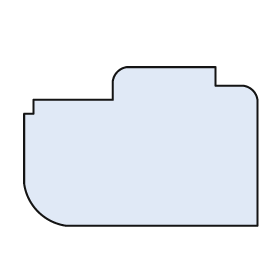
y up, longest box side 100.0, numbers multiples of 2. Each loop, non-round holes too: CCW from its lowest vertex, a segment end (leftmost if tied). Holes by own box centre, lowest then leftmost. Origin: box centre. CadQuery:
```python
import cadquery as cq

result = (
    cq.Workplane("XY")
    .moveTo(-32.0, -34.0)
    .lineTo(50.0, -34.0)
    .lineTo(50.0, 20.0)
    .threePointArc((48.0, 24.0), (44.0, 26.0))
    .lineTo(32.0, 26.0)
    .lineTo(32.0, 34.0)
    .lineTo(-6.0, 34.0)
    .threePointArc((-10.0, 32.0), (-12.0, 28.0))
    .lineTo(-12.0, 20.0)
    .lineTo(-46.0, 20.0)
    .lineTo(-46.0, 14.0)
    .lineTo(-50.0, 14.0)
    .lineTo(-50.0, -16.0)
    .threePointArc((-44.0, -28.0), (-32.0, -34.0))
    .close()
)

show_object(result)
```